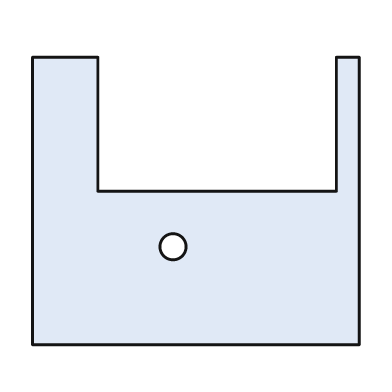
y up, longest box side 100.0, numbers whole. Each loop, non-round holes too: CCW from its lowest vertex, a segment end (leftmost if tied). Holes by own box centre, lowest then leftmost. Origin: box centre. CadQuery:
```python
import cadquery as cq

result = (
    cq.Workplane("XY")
    .moveTo(-50.0, -44.0)
    .lineTo(50.0, -44.0)
    .lineTo(50.0, 44.0)
    .lineTo(43.0, 44.0)
    .lineTo(43.0, 3.0)
    .lineTo(-30.0, 3.0)
    .lineTo(-30.0, 44.0)
    .lineTo(-50.0, 44.0)
    .close()
    .moveTo(-7.0, -14.0)
    .circle(4.0)
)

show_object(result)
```